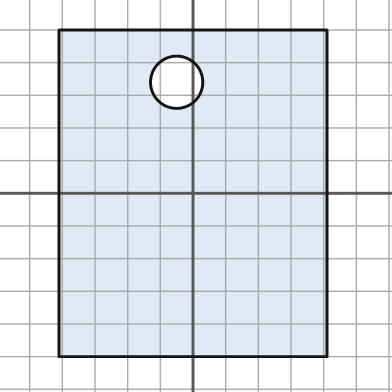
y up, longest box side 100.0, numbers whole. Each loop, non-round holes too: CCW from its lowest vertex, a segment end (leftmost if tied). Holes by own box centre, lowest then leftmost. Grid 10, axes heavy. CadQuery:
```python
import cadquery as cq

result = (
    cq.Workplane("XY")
    .moveTo(-41.0, -50.0)
    .lineTo(41.0, -50.0)
    .lineTo(41.0, 50.0)
    .lineTo(-41.0, 50.0)
    .close()
    .moveTo(-5.0, 34.0)
    .circle(8.0)
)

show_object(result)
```